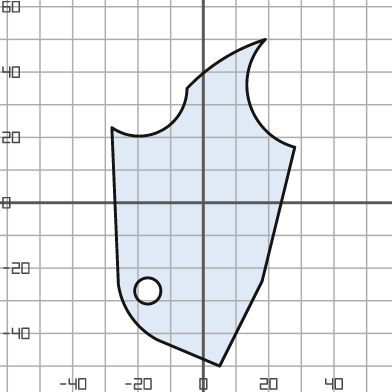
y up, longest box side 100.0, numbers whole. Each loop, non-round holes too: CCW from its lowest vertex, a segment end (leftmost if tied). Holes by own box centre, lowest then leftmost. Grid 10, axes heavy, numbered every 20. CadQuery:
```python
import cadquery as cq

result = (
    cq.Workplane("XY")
    .moveTo(5.0, -50.0)
    .lineTo(18.0, -24.0)
    .lineTo(28.0, 17.0)
    .threePointArc((14.0, 31.0), (19.0, 50.0))
    .threePointArc((6.0, 44.0), (-5.0, 35.0))
    .threePointArc((-13.0, 22.0), (-28.0, 23.0))
    .lineTo(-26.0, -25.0)
    .threePointArc((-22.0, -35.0), (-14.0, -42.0))
    .close()
    .moveTo(-17.0, -27.0)
    .circle(4.0)
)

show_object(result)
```